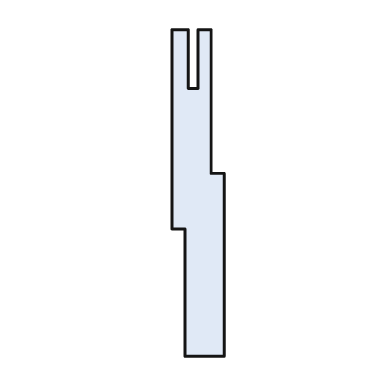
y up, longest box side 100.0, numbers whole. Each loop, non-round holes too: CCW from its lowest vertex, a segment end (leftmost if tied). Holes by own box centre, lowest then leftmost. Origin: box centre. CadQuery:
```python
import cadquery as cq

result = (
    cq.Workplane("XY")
    .moveTo(-4.0, -50.0)
    .lineTo(8.0, -50.0)
    .lineTo(8.0, 6.0)
    .lineTo(4.0, 6.0)
    .lineTo(4.0, 50.0)
    .lineTo(0.0, 50.0)
    .lineTo(0.0, 32.0)
    .lineTo(-3.0, 32.0)
    .lineTo(-3.0, 50.0)
    .lineTo(-8.0, 50.0)
    .lineTo(-8.0, -11.0)
    .lineTo(-4.0, -11.0)
    .close()
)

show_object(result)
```